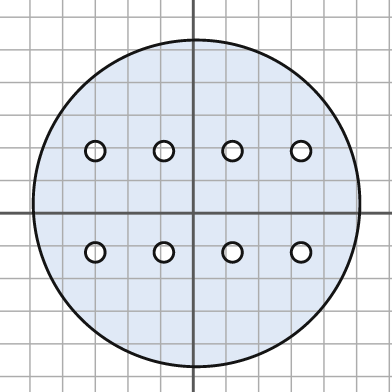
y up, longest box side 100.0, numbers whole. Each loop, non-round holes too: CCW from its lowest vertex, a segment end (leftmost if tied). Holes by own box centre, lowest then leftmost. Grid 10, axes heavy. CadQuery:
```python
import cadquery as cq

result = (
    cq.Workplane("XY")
    .moveTo(1.0, 3.0)
    .circle(50.0)
    .moveTo(-30.0, -12.0)
    .circle(3.0)
    .moveTo(-9.0, -12.0)
    .circle(3.0)
    .moveTo(12.0, -12.0)
    .circle(3.0)
    .moveTo(33.0, -12.0)
    .circle(3.0)
    .moveTo(-30.0, 19.0)
    .circle(3.0)
    .moveTo(-9.0, 19.0)
    .circle(3.0)
    .moveTo(12.0, 19.0)
    .circle(3.0)
    .moveTo(33.0, 19.0)
    .circle(3.0)
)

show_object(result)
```